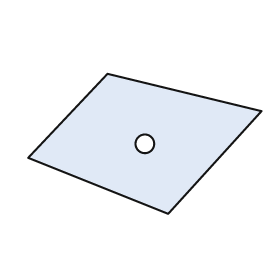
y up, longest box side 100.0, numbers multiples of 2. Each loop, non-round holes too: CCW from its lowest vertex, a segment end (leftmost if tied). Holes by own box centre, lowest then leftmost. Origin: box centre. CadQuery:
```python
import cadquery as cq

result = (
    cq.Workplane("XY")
    .moveTo(10.0, -30.0)
    .lineTo(50.0, 14.0)
    .lineTo(-16.0, 30.0)
    .lineTo(-50.0, -6.0)
    .close()
    .moveTo(0.0, 0.0)
    .circle(4.0)
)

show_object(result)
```